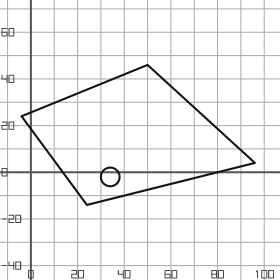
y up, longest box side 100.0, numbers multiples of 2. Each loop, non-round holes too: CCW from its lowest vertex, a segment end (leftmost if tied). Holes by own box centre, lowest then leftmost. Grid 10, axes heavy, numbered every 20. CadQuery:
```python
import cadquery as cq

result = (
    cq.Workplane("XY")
    .moveTo(24.0, -14.0)
    .lineTo(96.0, 4.0)
    .lineTo(50.0, 46.0)
    .lineTo(-4.0, 24.0)
    .close()
    .moveTo(34.0, -2.0)
    .circle(4.0)
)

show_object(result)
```